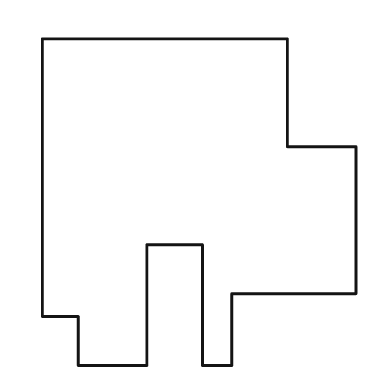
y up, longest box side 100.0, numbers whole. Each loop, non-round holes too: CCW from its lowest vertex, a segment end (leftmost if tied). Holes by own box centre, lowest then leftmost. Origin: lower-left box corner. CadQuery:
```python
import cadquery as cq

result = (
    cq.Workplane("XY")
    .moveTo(11.0, 0.0)
    .lineTo(32.0, 0.0)
    .lineTo(32.0, 37.0)
    .lineTo(49.0, 37.0)
    .lineTo(49.0, 0.0)
    .lineTo(58.0, 0.0)
    .lineTo(58.0, 22.0)
    .lineTo(96.0, 22.0)
    .lineTo(96.0, 67.0)
    .lineTo(75.0, 67.0)
    .lineTo(75.0, 100.0)
    .lineTo(0.0, 100.0)
    .lineTo(0.0, 15.0)
    .lineTo(11.0, 15.0)
    .close()
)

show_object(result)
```